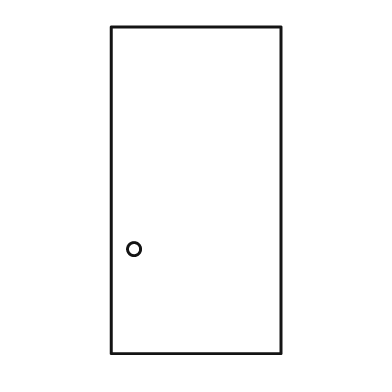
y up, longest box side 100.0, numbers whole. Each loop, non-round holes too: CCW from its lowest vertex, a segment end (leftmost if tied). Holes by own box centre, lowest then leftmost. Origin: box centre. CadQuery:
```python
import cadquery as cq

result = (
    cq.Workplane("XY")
    .moveTo(-26.0, -50.0)
    .lineTo(26.0, -50.0)
    .lineTo(26.0, 50.0)
    .lineTo(-26.0, 50.0)
    .close()
    .moveTo(-19.0, -18.0)
    .circle(2.0)
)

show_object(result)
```